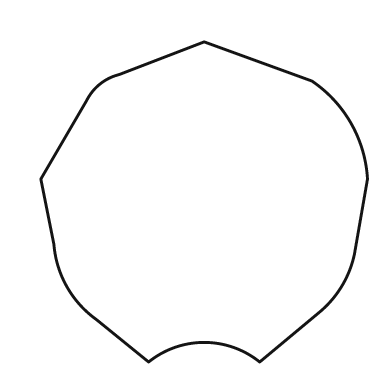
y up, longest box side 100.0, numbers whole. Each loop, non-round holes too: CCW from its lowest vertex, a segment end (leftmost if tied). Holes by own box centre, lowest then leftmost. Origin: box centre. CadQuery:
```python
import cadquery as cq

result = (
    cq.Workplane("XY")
    .moveTo(-17.0, -49.0)
    .threePointArc((0.0, -43.0), (17.0, -49.0))
    .lineTo(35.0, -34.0)
    .threePointArc((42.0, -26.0), (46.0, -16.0))
    .lineTo(50.0, 7.0)
    .threePointArc((45.0, 24.0), (33.0, 37.0))
    .lineTo(0.0, 49.0)
    .lineTo(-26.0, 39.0)
    .threePointArc((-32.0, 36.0), (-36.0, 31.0))
    .lineTo(-50.0, 7.0)
    .lineTo(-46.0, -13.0)
    .threePointArc((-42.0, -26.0), (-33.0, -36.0))
    .close()
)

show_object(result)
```